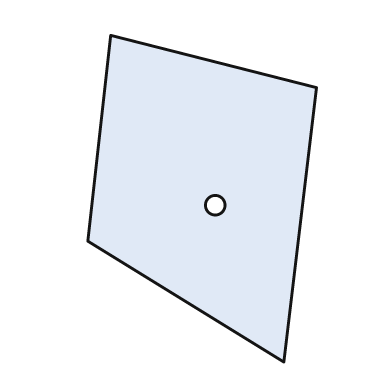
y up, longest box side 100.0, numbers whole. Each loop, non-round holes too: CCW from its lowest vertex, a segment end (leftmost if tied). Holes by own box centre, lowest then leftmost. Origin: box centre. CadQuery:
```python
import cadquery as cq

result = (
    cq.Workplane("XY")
    .moveTo(25.0, -50.0)
    .lineTo(35.0, 34.0)
    .lineTo(-28.0, 50.0)
    .lineTo(-35.0, -13.0)
    .close()
    .moveTo(4.0, -2.0)
    .circle(3.0)
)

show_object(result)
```